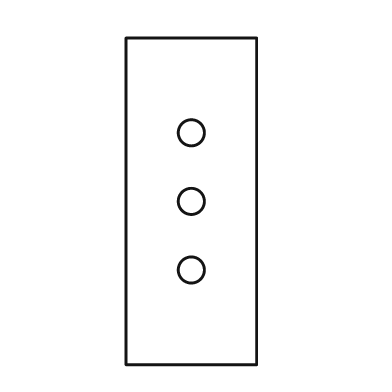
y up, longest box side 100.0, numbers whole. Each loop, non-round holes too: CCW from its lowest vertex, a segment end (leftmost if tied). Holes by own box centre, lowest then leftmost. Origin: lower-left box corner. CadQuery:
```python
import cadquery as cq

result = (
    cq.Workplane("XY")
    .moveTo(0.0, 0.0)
    .lineTo(40.0, 0.0)
    .lineTo(40.0, 100.0)
    .lineTo(0.0, 100.0)
    .close()
    .moveTo(20.0, 29.0)
    .circle(4.0)
    .moveTo(20.0, 50.0)
    .circle(4.0)
    .moveTo(20.0, 71.0)
    .circle(4.0)
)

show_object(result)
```